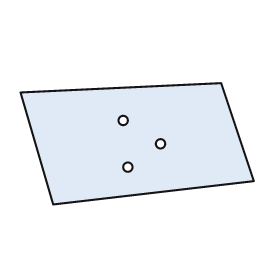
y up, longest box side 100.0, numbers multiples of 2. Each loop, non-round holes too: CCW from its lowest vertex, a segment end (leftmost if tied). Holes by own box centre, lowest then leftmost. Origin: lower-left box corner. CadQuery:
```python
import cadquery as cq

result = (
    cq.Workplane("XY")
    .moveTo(14.0, 0.0)
    .lineTo(100.0, 10.0)
    .lineTo(86.0, 52.0)
    .lineTo(0.0, 48.0)
    .close()
    .moveTo(46.0, 16.0)
    .circle(2.0)
    .moveTo(60.0, 26.0)
    .circle(2.0)
    .moveTo(44.0, 36.0)
    .circle(2.0)
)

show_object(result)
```